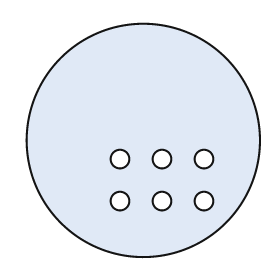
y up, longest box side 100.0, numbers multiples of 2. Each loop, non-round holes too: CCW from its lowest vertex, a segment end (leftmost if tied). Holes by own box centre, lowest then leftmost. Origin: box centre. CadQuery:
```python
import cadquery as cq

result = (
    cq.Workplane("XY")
    .moveTo(0.0, 0.0)
    .circle(50.0)
    .moveTo(-10.0, -26.0)
    .circle(4.0)
    .moveTo(8.0, -26.0)
    .circle(4.0)
    .moveTo(26.0, -26.0)
    .circle(4.0)
    .moveTo(-10.0, -8.0)
    .circle(4.0)
    .moveTo(8.0, -8.0)
    .circle(4.0)
    .moveTo(26.0, -8.0)
    .circle(4.0)
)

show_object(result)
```